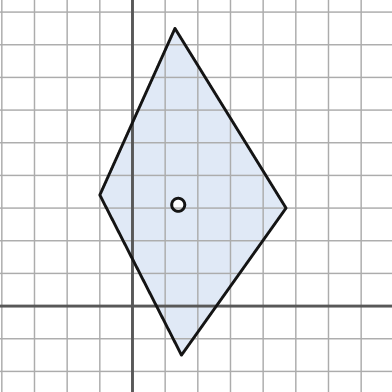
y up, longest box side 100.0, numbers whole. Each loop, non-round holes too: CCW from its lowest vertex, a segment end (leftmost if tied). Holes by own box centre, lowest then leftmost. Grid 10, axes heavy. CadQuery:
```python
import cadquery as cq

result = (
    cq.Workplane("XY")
    .moveTo(15.0, -15.0)
    .lineTo(47.0, 30.0)
    .lineTo(13.0, 85.0)
    .lineTo(-10.0, 34.0)
    .close()
    .moveTo(14.0, 31.0)
    .circle(2.0)
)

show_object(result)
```